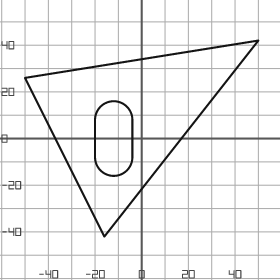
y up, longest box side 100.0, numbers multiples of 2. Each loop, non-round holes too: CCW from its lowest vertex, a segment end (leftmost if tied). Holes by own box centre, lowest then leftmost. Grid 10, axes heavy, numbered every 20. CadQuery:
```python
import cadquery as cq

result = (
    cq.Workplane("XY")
    .moveTo(-16.0, -42.0)
    .lineTo(50.0, 42.0)
    .lineTo(-50.0, 26.0)
    .close()
    .moveTo(-20.0, -8.0)
    .threePointArc((-12.0, -16.0), (-4.0, -8.0))
    .lineTo(-4.0, 8.0)
    .threePointArc((-12.0, 16.0), (-20.0, 8.0))
    .close()
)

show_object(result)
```